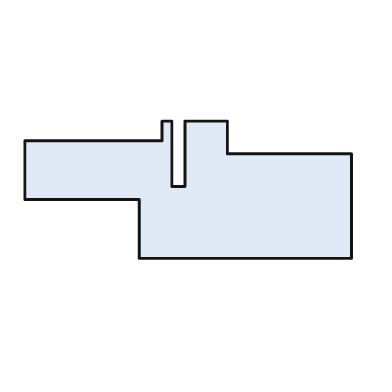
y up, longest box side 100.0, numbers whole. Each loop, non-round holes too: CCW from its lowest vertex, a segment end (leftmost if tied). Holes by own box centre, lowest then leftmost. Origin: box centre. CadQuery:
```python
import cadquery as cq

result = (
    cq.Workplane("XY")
    .moveTo(-15.0, -21.0)
    .lineTo(50.0, -21.0)
    .lineTo(50.0, 11.0)
    .lineTo(12.0, 11.0)
    .lineTo(12.0, 21.0)
    .lineTo(-1.0, 21.0)
    .lineTo(-1.0, 1.0)
    .lineTo(-5.0, 1.0)
    .lineTo(-5.0, 21.0)
    .lineTo(-8.0, 21.0)
    .lineTo(-8.0, 15.0)
    .lineTo(-50.0, 15.0)
    .lineTo(-50.0, -3.0)
    .lineTo(-15.0, -3.0)
    .close()
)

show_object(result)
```